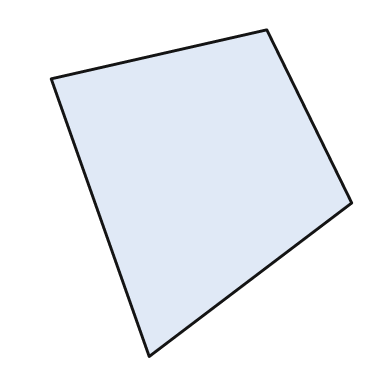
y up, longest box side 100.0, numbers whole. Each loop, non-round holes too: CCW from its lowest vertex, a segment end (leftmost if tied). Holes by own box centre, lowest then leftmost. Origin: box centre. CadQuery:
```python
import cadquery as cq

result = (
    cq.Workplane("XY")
    .moveTo(-16.0, -50.0)
    .lineTo(46.0, -3.0)
    .lineTo(20.0, 50.0)
    .lineTo(-46.0, 35.0)
    .close()
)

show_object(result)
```